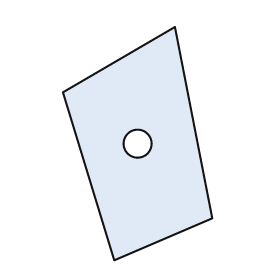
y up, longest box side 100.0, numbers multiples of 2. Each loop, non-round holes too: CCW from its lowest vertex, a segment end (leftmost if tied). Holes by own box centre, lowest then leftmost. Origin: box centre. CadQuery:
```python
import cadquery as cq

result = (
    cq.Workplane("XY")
    .moveTo(-10.0, -50.0)
    .lineTo(32.0, -32.0)
    .lineTo(16.0, 50.0)
    .lineTo(-32.0, 22.0)
    .close()
    .moveTo(0.0, 0.0)
    .circle(6.0)
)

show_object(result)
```